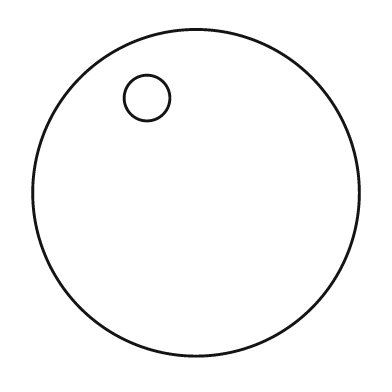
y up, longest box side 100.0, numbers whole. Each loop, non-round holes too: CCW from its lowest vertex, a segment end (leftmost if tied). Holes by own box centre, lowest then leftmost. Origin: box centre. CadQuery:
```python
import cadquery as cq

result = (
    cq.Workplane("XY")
    .moveTo(0.0, 0.0)
    .circle(50.0)
    .moveTo(-15.0, 29.0)
    .circle(7.0)
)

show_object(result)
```